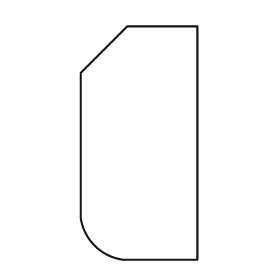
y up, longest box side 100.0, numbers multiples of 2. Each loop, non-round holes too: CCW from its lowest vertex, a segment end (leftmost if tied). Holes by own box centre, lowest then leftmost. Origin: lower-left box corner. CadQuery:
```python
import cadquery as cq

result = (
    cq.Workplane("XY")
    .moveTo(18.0, 0.0)
    .lineTo(50.0, 0.0)
    .lineTo(50.0, 100.0)
    .lineTo(20.0, 100.0)
    .lineTo(0.0, 80.0)
    .lineTo(0.0, 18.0)
    .threePointArc((6.0, 6.0), (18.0, 0.0))
    .close()
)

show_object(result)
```